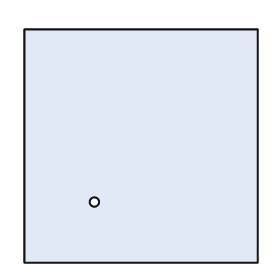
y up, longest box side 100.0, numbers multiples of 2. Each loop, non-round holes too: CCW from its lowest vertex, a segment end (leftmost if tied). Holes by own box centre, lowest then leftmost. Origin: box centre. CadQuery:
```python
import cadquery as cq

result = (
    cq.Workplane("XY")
    .moveTo(-50.0, -50.0)
    .lineTo(50.0, -50.0)
    .lineTo(50.0, 50.0)
    .lineTo(-50.0, 50.0)
    .close()
    .moveTo(-20.0, -24.0)
    .circle(2.0)
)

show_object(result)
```